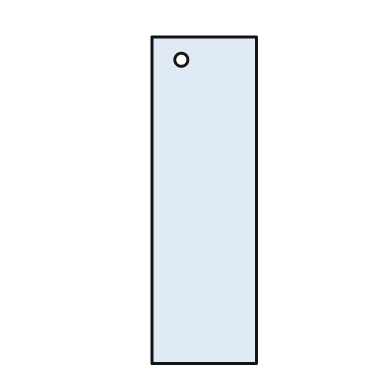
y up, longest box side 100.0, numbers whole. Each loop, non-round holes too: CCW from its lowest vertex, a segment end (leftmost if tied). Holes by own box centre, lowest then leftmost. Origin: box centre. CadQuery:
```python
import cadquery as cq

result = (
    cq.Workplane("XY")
    .moveTo(-16.0, -50.0)
    .lineTo(16.0, -50.0)
    .lineTo(16.0, 50.0)
    .lineTo(-16.0, 50.0)
    .close()
    .moveTo(-7.0, 43.0)
    .circle(2.0)
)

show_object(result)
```